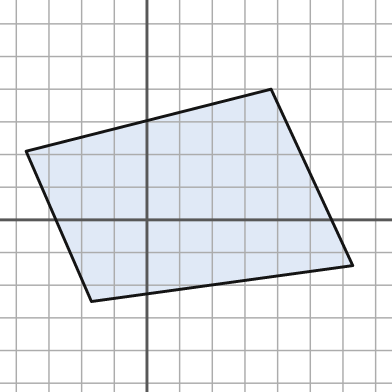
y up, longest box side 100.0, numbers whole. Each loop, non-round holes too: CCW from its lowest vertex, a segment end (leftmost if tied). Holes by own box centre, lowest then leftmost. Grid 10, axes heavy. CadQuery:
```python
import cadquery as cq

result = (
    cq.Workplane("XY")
    .moveTo(-17.0, -25.0)
    .lineTo(63.0, -14.0)
    .lineTo(38.0, 40.0)
    .lineTo(-37.0, 21.0)
    .close()
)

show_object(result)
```